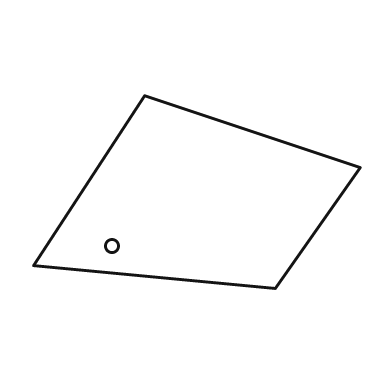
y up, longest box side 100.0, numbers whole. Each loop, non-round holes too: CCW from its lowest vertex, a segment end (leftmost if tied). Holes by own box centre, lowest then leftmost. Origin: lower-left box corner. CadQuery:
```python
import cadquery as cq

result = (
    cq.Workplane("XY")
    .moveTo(74.0, 0.0)
    .lineTo(100.0, 37.0)
    .lineTo(34.0, 59.0)
    .lineTo(0.0, 7.0)
    .close()
    .moveTo(24.0, 13.0)
    .circle(2.0)
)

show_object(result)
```